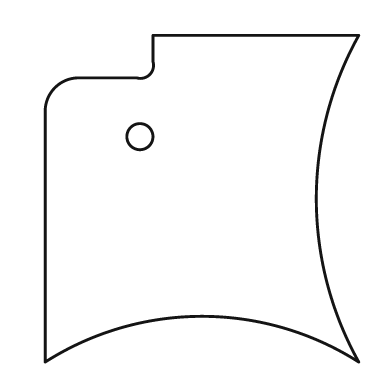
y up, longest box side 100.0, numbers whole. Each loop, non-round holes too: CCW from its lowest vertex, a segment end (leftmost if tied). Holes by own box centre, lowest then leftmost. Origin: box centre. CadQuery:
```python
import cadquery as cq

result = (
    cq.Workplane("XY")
    .moveTo(-48.0, -50.0)
    .threePointArc((0.0, -36.0), (48.0, -50.0))
    .threePointArc((35.0, 0.0), (48.0, 50.0))
    .lineTo(-15.0, 50.0)
    .lineTo(-15.0, 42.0)
    .threePointArc((-16.0, 38.0), (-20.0, 37.0))
    .lineTo(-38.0, 37.0)
    .threePointArc((-45.0, 34.0), (-48.0, 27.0))
    .close()
    .moveTo(-19.0, 19.0)
    .circle(4.0)
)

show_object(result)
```